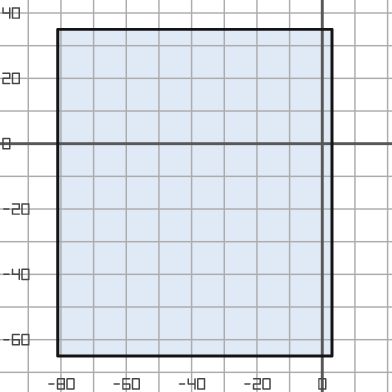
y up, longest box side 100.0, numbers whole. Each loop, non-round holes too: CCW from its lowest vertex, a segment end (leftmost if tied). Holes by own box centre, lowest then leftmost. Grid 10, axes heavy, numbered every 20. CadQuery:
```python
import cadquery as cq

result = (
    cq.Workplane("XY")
    .moveTo(-81.0, -65.0)
    .lineTo(3.0, -65.0)
    .lineTo(3.0, 35.0)
    .lineTo(-81.0, 35.0)
    .close()
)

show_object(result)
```